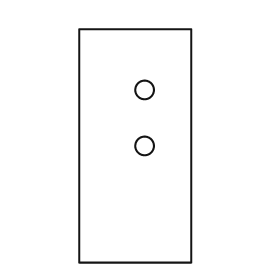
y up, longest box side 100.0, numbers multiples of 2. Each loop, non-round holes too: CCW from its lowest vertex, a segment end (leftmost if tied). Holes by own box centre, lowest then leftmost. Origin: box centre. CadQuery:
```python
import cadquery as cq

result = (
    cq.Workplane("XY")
    .moveTo(-24.0, -50.0)
    .lineTo(24.0, -50.0)
    .lineTo(24.0, 50.0)
    .lineTo(-24.0, 50.0)
    .close()
    .moveTo(4.0, 0.0)
    .circle(4.0)
    .moveTo(4.0, 24.0)
    .circle(4.0)
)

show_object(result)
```